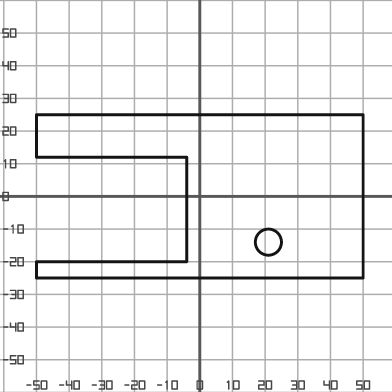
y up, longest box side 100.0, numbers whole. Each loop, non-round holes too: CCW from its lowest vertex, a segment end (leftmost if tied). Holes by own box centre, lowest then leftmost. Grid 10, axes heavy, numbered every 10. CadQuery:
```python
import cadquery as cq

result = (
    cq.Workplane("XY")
    .moveTo(-50.0, -25.0)
    .lineTo(50.0, -25.0)
    .lineTo(50.0, 25.0)
    .lineTo(-50.0, 25.0)
    .lineTo(-50.0, 12.0)
    .lineTo(-4.0, 12.0)
    .lineTo(-4.0, -20.0)
    .lineTo(-50.0, -20.0)
    .close()
    .moveTo(21.0, -14.0)
    .circle(4.0)
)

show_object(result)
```